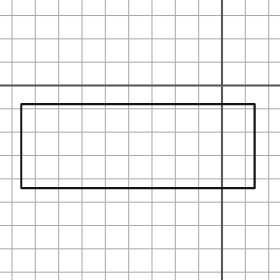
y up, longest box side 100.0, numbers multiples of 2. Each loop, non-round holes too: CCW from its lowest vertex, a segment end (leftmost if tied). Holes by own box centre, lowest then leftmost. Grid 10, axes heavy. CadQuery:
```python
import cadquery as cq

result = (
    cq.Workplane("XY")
    .moveTo(-86.0, -44.0)
    .lineTo(14.0, -44.0)
    .lineTo(14.0, -8.0)
    .lineTo(-86.0, -8.0)
    .close()
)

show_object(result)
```